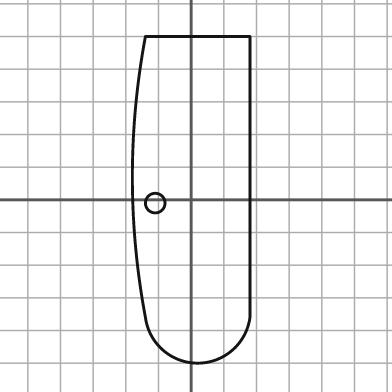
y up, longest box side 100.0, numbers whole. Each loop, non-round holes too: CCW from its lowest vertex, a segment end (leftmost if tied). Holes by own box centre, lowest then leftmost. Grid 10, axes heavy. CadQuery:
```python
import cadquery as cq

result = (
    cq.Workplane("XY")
    .moveTo(-14.0, -36.0)
    .threePointArc((2.0, -50.0), (18.0, -36.0))
    .lineTo(18.0, 50.0)
    .lineTo(-14.0, 50.0)
    .threePointArc((-18.0, 7.0), (-14.0, -36.0))
    .close()
    .moveTo(-11.0, -1.0)
    .circle(3.0)
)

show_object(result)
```